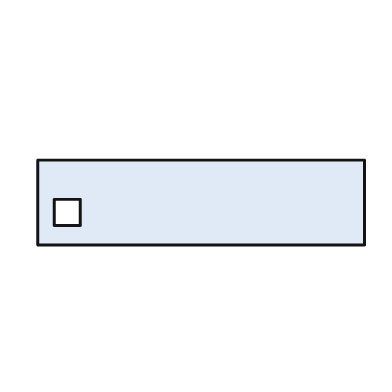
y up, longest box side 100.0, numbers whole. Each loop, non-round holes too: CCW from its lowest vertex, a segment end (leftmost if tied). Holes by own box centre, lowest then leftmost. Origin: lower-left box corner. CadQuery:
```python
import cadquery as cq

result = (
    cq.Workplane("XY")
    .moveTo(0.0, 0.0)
    .lineTo(100.0, 0.0)
    .lineTo(100.0, 26.0)
    .lineTo(0.0, 26.0)
    .close()
    .moveTo(5.0, 6.0)
    .lineTo(13.0, 6.0)
    .lineTo(13.0, 14.0)
    .lineTo(5.0, 14.0)
    .close()
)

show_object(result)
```